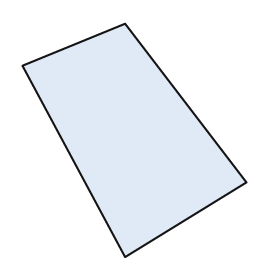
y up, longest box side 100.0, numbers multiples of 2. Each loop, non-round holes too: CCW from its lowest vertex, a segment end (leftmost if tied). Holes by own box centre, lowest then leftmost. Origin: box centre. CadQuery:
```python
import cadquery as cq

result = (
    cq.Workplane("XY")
    .moveTo(-4.0, -50.0)
    .lineTo(48.0, -18.0)
    .lineTo(-4.0, 50.0)
    .lineTo(-48.0, 32.0)
    .close()
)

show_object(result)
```